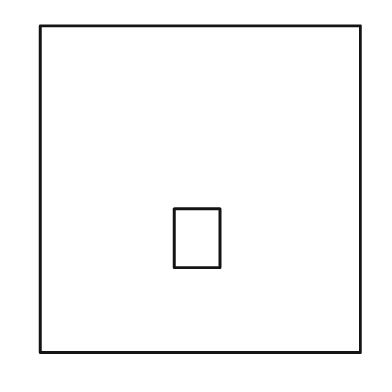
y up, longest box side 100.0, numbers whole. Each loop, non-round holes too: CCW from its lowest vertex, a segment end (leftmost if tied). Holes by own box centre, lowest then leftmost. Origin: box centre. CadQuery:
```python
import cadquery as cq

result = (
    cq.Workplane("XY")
    .moveTo(-49.0, -50.0)
    .lineTo(49.0, -50.0)
    .lineTo(49.0, 50.0)
    .lineTo(-49.0, 50.0)
    .close()
    .moveTo(-8.0, -24.0)
    .lineTo(6.0, -24.0)
    .lineTo(6.0, -6.0)
    .lineTo(-8.0, -6.0)
    .close()
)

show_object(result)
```